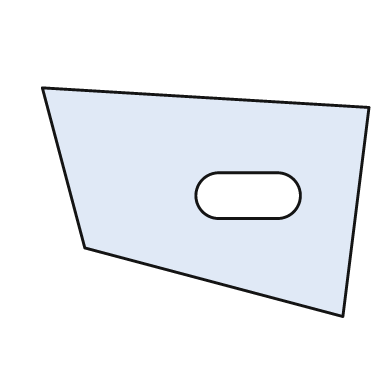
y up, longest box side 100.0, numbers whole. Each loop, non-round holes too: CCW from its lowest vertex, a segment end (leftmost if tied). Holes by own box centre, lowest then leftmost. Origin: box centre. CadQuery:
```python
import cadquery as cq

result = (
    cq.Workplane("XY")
    .moveTo(42.0, -35.0)
    .lineTo(50.0, 29.0)
    .lineTo(-50.0, 35.0)
    .lineTo(-37.0, -14.0)
    .close()
    .moveTo(4.0, -5.0)
    .lineTo(22.0, -5.0)
    .threePointArc((29.0, 2.0), (22.0, 9.0))
    .lineTo(4.0, 9.0)
    .threePointArc((-3.0, 2.0), (4.0, -5.0))
    .close()
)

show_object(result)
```